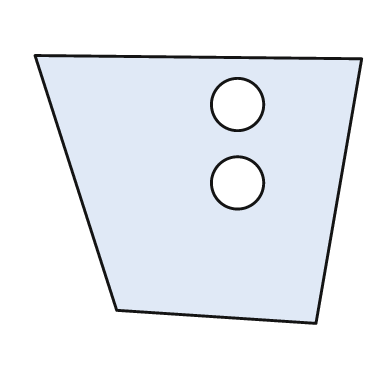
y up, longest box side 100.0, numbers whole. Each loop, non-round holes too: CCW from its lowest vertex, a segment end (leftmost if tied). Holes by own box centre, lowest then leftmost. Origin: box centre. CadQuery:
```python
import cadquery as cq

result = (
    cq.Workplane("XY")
    .moveTo(36.0, -41.0)
    .lineTo(50.0, 40.0)
    .lineTo(-50.0, 41.0)
    .lineTo(-25.0, -37.0)
    .close()
    .moveTo(12.0, 2.0)
    .circle(8.0)
    .moveTo(12.0, 26.0)
    .circle(8.0)
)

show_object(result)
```